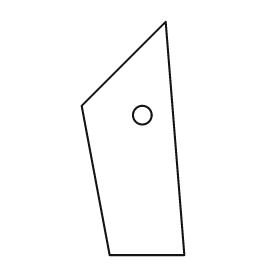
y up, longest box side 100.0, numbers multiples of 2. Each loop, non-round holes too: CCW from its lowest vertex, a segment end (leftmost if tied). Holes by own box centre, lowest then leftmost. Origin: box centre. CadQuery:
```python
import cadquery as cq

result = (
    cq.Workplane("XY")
    .moveTo(-10.0, -50.0)
    .lineTo(22.0, -50.0)
    .lineTo(14.0, 50.0)
    .lineTo(-22.0, 14.0)
    .close()
    .moveTo(4.0, 10.0)
    .circle(4.0)
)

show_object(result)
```